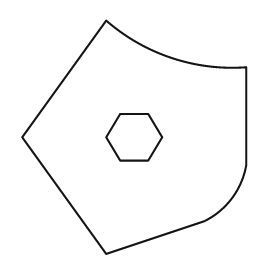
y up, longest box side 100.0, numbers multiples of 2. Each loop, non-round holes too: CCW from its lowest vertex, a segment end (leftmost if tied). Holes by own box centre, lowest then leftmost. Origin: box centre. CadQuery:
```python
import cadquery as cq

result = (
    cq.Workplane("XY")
    .moveTo(-12.0, -50.0)
    .lineTo(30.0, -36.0)
    .threePointArc((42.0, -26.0), (48.0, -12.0))
    .lineTo(48.0, 30.0)
    .threePointArc((16.0, 34.0), (-12.0, 50.0))
    .lineTo(-48.0, 0.0)
    .close()
    .moveTo(-6.0, -10.0)
    .lineTo(6.0, -10.0)
    .lineTo(12.0, 0.0)
    .lineTo(6.0, 10.0)
    .lineTo(-6.0, 10.0)
    .lineTo(-12.0, 0.0)
    .close()
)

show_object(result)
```